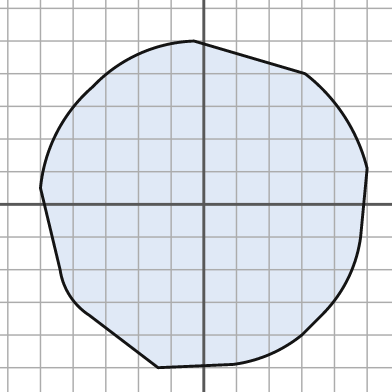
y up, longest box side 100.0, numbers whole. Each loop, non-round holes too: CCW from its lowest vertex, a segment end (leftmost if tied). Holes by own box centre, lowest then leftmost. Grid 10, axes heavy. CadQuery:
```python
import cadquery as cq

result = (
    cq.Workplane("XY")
    .moveTo(-14.0, -50.0)
    .lineTo(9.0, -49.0)
    .threePointArc((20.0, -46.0), (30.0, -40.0))
    .lineTo(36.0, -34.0)
    .threePointArc((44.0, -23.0), (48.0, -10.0))
    .lineTo(50.0, 11.0)
    .threePointArc((43.0, 27.0), (31.0, 40.0))
    .lineTo(-3.0, 50.0)
    .threePointArc((-20.0, 46.0), (-34.0, 36.0))
    .threePointArc((-45.0, 22.0), (-50.0, 5.0))
    .lineTo(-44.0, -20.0)
    .threePointArc((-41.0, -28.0), (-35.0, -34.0))
    .close()
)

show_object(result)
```